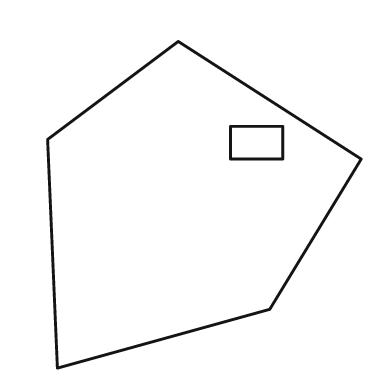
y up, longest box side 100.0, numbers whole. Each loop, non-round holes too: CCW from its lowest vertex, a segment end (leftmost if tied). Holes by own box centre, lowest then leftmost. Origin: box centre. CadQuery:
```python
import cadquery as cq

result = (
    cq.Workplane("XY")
    .moveTo(-45.0, -50.0)
    .lineTo(20.0, -32.0)
    .lineTo(48.0, 14.0)
    .lineTo(-8.0, 50.0)
    .lineTo(-48.0, 20.0)
    .close()
    .moveTo(8.0, 14.0)
    .lineTo(24.0, 14.0)
    .lineTo(24.0, 24.0)
    .lineTo(8.0, 24.0)
    .close()
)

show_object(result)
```